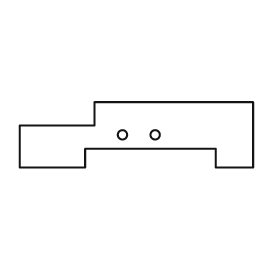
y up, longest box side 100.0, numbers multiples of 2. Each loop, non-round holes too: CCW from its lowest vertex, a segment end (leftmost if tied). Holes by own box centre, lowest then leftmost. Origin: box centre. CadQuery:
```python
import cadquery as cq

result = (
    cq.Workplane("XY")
    .moveTo(-50.0, -14.0)
    .lineTo(-22.0, -14.0)
    .lineTo(-22.0, -6.0)
    .lineTo(34.0, -6.0)
    .lineTo(34.0, -14.0)
    .lineTo(50.0, -14.0)
    .lineTo(50.0, 14.0)
    .lineTo(-18.0, 14.0)
    .lineTo(-18.0, 4.0)
    .lineTo(-50.0, 4.0)
    .close()
    .moveTo(-6.0, 0.0)
    .circle(2.0)
    .moveTo(8.0, 0.0)
    .circle(2.0)
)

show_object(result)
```